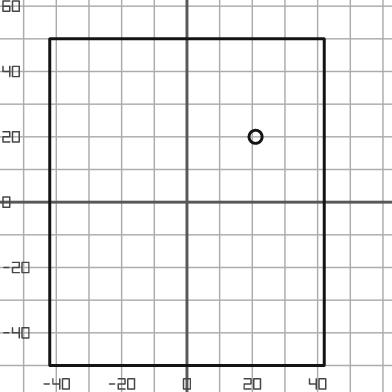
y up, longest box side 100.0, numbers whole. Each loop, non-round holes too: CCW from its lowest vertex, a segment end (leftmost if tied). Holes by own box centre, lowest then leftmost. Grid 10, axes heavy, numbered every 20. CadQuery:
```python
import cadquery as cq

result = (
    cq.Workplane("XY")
    .moveTo(-42.0, -50.0)
    .lineTo(42.0, -50.0)
    .lineTo(42.0, 50.0)
    .lineTo(-42.0, 50.0)
    .close()
    .moveTo(21.0, 20.0)
    .circle(2.0)
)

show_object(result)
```